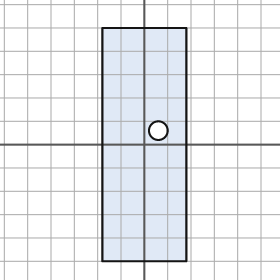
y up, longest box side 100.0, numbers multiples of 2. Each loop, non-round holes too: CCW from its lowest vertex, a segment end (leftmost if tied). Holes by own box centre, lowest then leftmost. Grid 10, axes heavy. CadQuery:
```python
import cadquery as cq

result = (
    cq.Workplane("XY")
    .moveTo(-18.0, -50.0)
    .lineTo(18.0, -50.0)
    .lineTo(18.0, 50.0)
    .lineTo(-18.0, 50.0)
    .close()
    .moveTo(6.0, 6.0)
    .circle(4.0)
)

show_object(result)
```